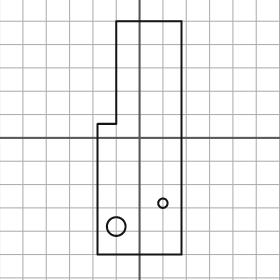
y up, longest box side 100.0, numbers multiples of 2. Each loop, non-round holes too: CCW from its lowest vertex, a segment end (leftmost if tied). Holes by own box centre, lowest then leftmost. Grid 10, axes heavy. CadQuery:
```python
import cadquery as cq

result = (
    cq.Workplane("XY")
    .moveTo(-18.0, -50.0)
    .lineTo(18.0, -50.0)
    .lineTo(18.0, 50.0)
    .lineTo(-10.0, 50.0)
    .lineTo(-10.0, 6.0)
    .lineTo(-18.0, 6.0)
    .close()
    .moveTo(-10.0, -38.0)
    .circle(4.0)
    .moveTo(10.0, -28.0)
    .circle(2.0)
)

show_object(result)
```